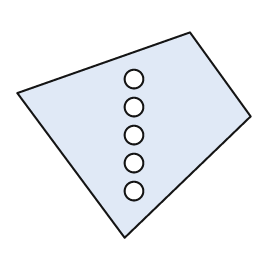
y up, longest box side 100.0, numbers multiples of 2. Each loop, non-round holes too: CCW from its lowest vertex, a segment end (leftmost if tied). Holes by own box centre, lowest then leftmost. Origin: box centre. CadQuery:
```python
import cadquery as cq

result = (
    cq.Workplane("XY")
    .moveTo(-4.0, -44.0)
    .lineTo(50.0, 8.0)
    .lineTo(24.0, 44.0)
    .lineTo(-50.0, 18.0)
    .close()
    .moveTo(0.0, -24.0)
    .circle(4.0)
    .moveTo(0.0, -12.0)
    .circle(4.0)
    .moveTo(0.0, 0.0)
    .circle(4.0)
    .moveTo(0.0, 12.0)
    .circle(4.0)
    .moveTo(0.0, 24.0)
    .circle(4.0)
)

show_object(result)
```